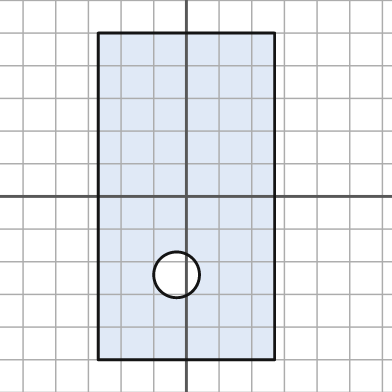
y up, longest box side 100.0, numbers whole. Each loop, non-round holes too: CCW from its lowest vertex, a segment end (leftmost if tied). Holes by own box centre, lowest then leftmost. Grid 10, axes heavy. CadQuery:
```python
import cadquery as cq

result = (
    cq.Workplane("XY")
    .moveTo(-27.0, -50.0)
    .lineTo(27.0, -50.0)
    .lineTo(27.0, 50.0)
    .lineTo(-27.0, 50.0)
    .close()
    .moveTo(-3.0, -24.0)
    .circle(7.0)
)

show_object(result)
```